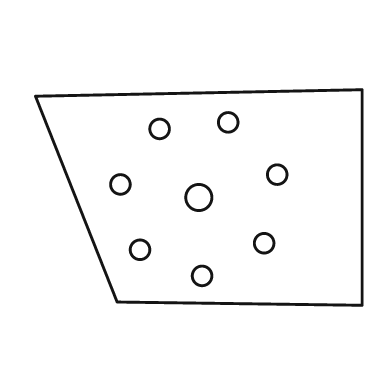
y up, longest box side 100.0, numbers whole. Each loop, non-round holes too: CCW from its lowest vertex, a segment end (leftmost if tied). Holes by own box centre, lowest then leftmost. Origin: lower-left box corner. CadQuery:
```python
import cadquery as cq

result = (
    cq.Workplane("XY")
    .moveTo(100.0, 0.0)
    .lineTo(100.0, 66.0)
    .lineTo(0.0, 64.0)
    .lineTo(25.0, 1.0)
    .close()
    .moveTo(51.0, 9.0)
    .circle(3.0)
    .moveTo(32.0, 17.0)
    .circle(3.0)
    .moveTo(70.0, 19.0)
    .circle(3.0)
    .moveTo(50.0, 33.0)
    .circle(4.0)
    .moveTo(26.0, 37.0)
    .circle(3.0)
    .moveTo(74.0, 40.0)
    .circle(3.0)
    .moveTo(38.0, 54.0)
    .circle(3.0)
    .moveTo(59.0, 56.0)
    .circle(3.0)
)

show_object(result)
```